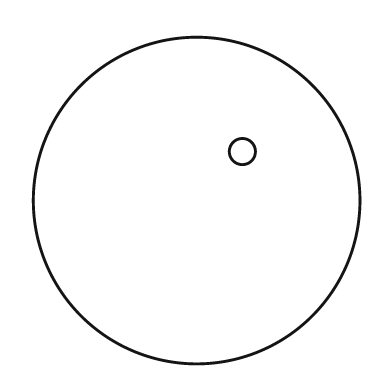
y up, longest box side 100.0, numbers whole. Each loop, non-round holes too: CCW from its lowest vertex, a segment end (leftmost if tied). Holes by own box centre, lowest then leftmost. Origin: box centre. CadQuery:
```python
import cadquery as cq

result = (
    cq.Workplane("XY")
    .moveTo(0.0, 0.0)
    .circle(50.0)
    .moveTo(14.0, 15.0)
    .circle(4.0)
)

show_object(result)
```